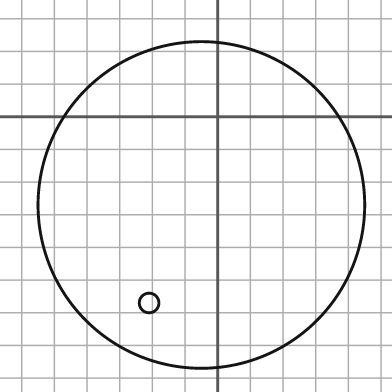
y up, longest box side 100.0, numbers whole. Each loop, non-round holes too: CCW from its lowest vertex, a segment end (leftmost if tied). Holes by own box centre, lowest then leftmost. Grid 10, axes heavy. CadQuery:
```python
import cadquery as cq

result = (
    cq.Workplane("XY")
    .moveTo(-5.0, -27.0)
    .circle(50.0)
    .moveTo(-21.0, -57.0)
    .circle(3.0)
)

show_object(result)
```